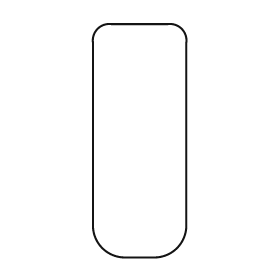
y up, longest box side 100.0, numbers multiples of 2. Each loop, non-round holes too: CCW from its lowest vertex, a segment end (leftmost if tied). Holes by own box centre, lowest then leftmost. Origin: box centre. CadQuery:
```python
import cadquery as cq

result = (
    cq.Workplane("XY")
    .moveTo(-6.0, -50.0)
    .lineTo(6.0, -50.0)
    .threePointArc((16.0, -46.0), (20.0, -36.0))
    .lineTo(20.0, 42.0)
    .threePointArc((18.0, 48.0), (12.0, 50.0))
    .lineTo(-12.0, 50.0)
    .threePointArc((-18.0, 48.0), (-20.0, 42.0))
    .lineTo(-20.0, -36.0)
    .threePointArc((-16.0, -46.0), (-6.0, -50.0))
    .close()
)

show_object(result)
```